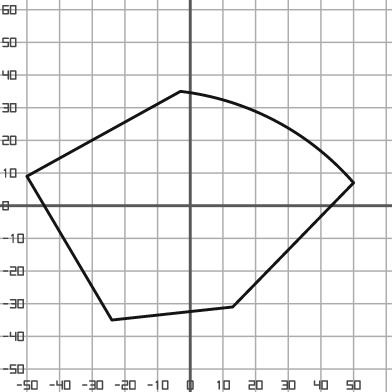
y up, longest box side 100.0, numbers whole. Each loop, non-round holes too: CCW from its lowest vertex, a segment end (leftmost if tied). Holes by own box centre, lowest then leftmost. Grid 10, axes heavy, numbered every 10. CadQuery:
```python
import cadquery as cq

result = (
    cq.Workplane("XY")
    .moveTo(-24.0, -35.0)
    .lineTo(13.0, -31.0)
    .lineTo(50.0, 7.0)
    .threePointArc((26.0, 26.0), (-3.0, 35.0))
    .lineTo(-50.0, 9.0)
    .close()
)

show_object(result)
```